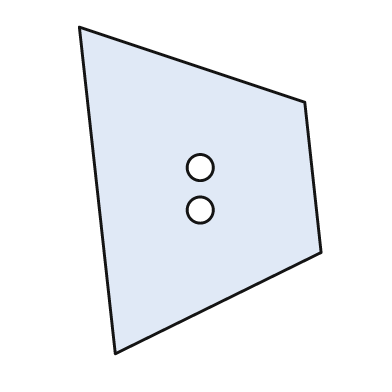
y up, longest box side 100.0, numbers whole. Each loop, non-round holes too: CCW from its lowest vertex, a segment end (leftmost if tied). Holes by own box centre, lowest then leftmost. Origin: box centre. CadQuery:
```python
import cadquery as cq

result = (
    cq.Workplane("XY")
    .moveTo(-26.0, -50.0)
    .lineTo(37.0, -19.0)
    .lineTo(32.0, 27.0)
    .lineTo(-37.0, 50.0)
    .close()
    .moveTo(0.0, -6.0)
    .circle(4.0)
    .moveTo(0.0, 7.0)
    .circle(4.0)
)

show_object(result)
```